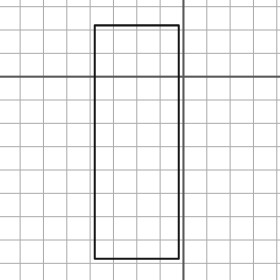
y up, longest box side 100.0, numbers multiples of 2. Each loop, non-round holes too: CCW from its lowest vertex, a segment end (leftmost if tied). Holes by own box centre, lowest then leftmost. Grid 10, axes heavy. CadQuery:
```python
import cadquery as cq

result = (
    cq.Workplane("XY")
    .moveTo(-38.0, -78.0)
    .lineTo(-2.0, -78.0)
    .lineTo(-2.0, 22.0)
    .lineTo(-38.0, 22.0)
    .close()
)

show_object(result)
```